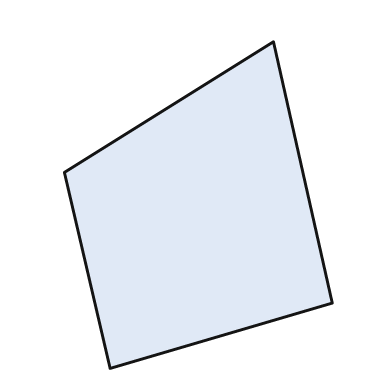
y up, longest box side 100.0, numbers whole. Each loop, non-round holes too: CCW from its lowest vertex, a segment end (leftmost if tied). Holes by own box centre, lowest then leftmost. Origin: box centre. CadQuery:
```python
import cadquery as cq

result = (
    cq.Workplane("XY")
    .moveTo(-27.0, -50.0)
    .lineTo(41.0, -30.0)
    .lineTo(23.0, 50.0)
    .lineTo(-41.0, 10.0)
    .close()
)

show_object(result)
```